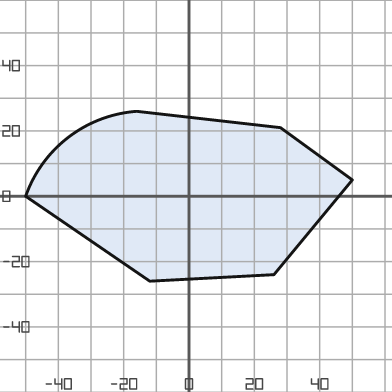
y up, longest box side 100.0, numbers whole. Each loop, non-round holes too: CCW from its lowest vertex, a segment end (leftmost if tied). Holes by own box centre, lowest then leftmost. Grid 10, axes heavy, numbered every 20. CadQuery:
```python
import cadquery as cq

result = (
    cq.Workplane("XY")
    .moveTo(-12.0, -26.0)
    .lineTo(26.0, -24.0)
    .lineTo(50.0, 5.0)
    .lineTo(28.0, 21.0)
    .lineTo(-16.0, 26.0)
    .threePointArc((-37.0, 18.0), (-50.0, 0.0))
    .close()
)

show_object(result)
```